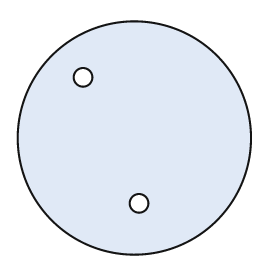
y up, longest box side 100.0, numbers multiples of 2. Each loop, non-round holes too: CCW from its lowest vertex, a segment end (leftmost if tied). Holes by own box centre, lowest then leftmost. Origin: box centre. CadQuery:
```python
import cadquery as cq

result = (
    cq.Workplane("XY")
    .moveTo(0.0, 0.0)
    .circle(50.0)
    .moveTo(2.0, -28.0)
    .circle(4.0)
    .moveTo(-22.0, 26.0)
    .circle(4.0)
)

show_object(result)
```